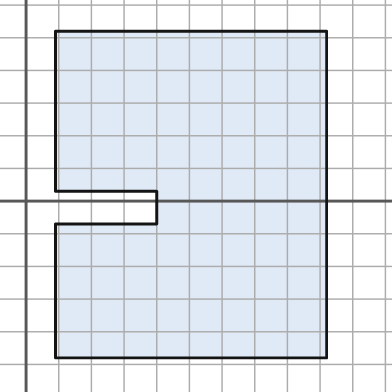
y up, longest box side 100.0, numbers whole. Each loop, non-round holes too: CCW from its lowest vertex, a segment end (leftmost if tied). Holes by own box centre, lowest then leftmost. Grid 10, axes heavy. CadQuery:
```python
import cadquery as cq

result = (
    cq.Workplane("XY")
    .moveTo(9.0, -48.0)
    .lineTo(92.0, -48.0)
    .lineTo(92.0, 52.0)
    .lineTo(9.0, 52.0)
    .lineTo(9.0, 3.0)
    .lineTo(40.0, 3.0)
    .lineTo(40.0, -7.0)
    .lineTo(9.0, -7.0)
    .close()
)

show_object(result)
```